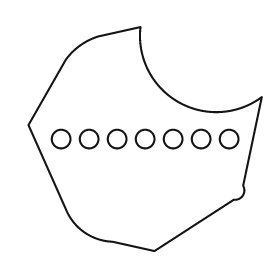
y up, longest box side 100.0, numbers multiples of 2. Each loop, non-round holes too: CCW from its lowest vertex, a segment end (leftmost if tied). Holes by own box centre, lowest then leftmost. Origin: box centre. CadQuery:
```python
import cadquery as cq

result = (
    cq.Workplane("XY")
    .moveTo(4.0, -48.0)
    .lineTo(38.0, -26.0)
    .threePointArc((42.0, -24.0), (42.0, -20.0))
    .lineTo(50.0, 18.0)
    .threePointArc((14.0, 16.0), (-2.0, 48.0))
    .lineTo(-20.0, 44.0)
    .threePointArc((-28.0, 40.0), (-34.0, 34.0))
    .lineTo(-50.0, 6.0)
    .lineTo(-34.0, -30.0)
    .threePointArc((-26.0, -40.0), (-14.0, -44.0))
    .close()
    .moveTo(-36.0, 0.0)
    .circle(4.0)
    .moveTo(-24.0, 0.0)
    .circle(4.0)
    .moveTo(-12.0, 0.0)
    .circle(4.0)
    .moveTo(0.0, 0.0)
    .circle(4.0)
    .moveTo(12.0, 0.0)
    .circle(4.0)
    .moveTo(24.0, 0.0)
    .circle(4.0)
    .moveTo(36.0, 0.0)
    .circle(4.0)
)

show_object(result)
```